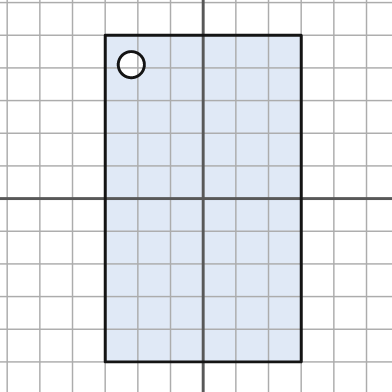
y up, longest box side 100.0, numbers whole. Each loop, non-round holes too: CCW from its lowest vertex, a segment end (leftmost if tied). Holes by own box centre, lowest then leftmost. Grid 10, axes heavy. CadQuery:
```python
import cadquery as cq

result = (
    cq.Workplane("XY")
    .moveTo(-30.0, -50.0)
    .lineTo(30.0, -50.0)
    .lineTo(30.0, 50.0)
    .lineTo(-30.0, 50.0)
    .close()
    .moveTo(-22.0, 41.0)
    .circle(4.0)
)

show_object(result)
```